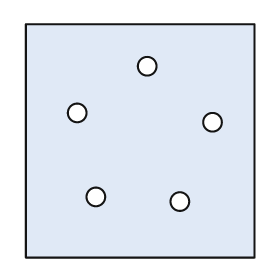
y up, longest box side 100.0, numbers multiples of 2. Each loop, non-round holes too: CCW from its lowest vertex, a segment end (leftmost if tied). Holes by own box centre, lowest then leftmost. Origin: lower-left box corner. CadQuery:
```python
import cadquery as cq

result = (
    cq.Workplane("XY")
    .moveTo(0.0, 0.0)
    .lineTo(98.0, 0.0)
    .lineTo(98.0, 100.0)
    .lineTo(0.0, 100.0)
    .close()
    .moveTo(66.0, 24.0)
    .circle(4.0)
    .moveTo(30.0, 26.0)
    .circle(4.0)
    .moveTo(80.0, 58.0)
    .circle(4.0)
    .moveTo(22.0, 62.0)
    .circle(4.0)
    .moveTo(52.0, 82.0)
    .circle(4.0)
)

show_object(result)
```